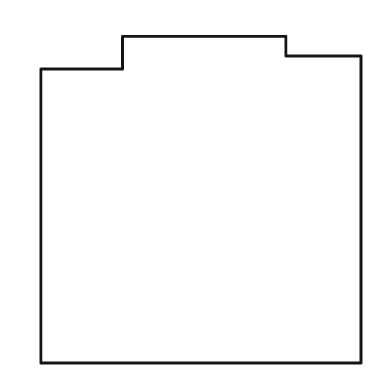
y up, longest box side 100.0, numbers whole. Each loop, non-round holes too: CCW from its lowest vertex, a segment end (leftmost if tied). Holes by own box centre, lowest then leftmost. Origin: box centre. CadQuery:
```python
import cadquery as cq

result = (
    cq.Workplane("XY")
    .moveTo(-49.0, -50.0)
    .lineTo(49.0, -50.0)
    .lineTo(49.0, 44.0)
    .lineTo(26.0, 44.0)
    .lineTo(26.0, 50.0)
    .lineTo(-24.0, 50.0)
    .lineTo(-24.0, 40.0)
    .lineTo(-49.0, 40.0)
    .close()
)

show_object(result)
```